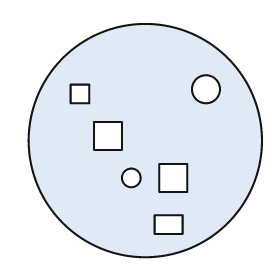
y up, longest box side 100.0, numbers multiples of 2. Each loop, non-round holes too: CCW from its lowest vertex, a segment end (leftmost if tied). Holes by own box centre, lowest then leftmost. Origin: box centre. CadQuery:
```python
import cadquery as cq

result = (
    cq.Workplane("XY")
    .moveTo(0.0, 0.0)
    .circle(50.0)
    .moveTo(4.0, -40.0)
    .lineTo(16.0, -40.0)
    .lineTo(16.0, -32.0)
    .lineTo(4.0, -32.0)
    .close()
    .moveTo(-6.0, -16.0)
    .circle(4.0)
    .moveTo(6.0, -22.0)
    .lineTo(18.0, -22.0)
    .lineTo(18.0, -10.0)
    .lineTo(6.0, -10.0)
    .close()
    .moveTo(-22.0, -4.0)
    .lineTo(-10.0, -4.0)
    .lineTo(-10.0, 8.0)
    .lineTo(-22.0, 8.0)
    .close()
    .moveTo(-32.0, 16.0)
    .lineTo(-24.0, 16.0)
    .lineTo(-24.0, 24.0)
    .lineTo(-32.0, 24.0)
    .close()
    .moveTo(26.0, 22.0)
    .circle(6.0)
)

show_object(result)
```